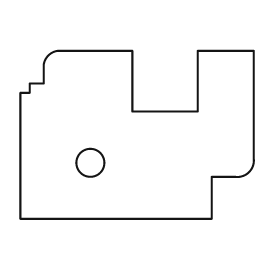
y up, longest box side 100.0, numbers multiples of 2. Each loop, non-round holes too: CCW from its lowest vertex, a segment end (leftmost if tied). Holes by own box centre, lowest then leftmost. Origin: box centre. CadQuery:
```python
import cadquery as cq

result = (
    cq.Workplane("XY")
    .moveTo(-50.0, -36.0)
    .lineTo(32.0, -36.0)
    .lineTo(32.0, -18.0)
    .lineTo(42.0, -18.0)
    .threePointArc((48.0, -16.0), (50.0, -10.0))
    .lineTo(50.0, 36.0)
    .lineTo(26.0, 36.0)
    .lineTo(26.0, 10.0)
    .lineTo(-2.0, 10.0)
    .lineTo(-2.0, 36.0)
    .lineTo(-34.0, 36.0)
    .threePointArc((-38.0, 34.0), (-40.0, 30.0))
    .lineTo(-40.0, 22.0)
    .lineTo(-46.0, 22.0)
    .lineTo(-46.0, 18.0)
    .lineTo(-50.0, 18.0)
    .close()
    .moveTo(-20.0, -12.0)
    .circle(6.0)
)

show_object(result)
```